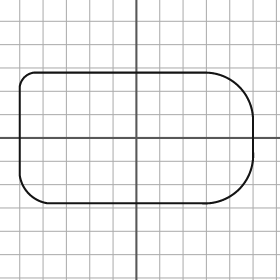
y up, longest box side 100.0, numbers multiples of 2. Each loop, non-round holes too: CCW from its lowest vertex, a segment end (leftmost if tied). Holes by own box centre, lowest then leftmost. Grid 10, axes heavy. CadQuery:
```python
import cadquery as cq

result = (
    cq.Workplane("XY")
    .moveTo(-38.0, -28.0)
    .lineTo(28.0, -28.0)
    .threePointArc((44.0, -22.0), (50.0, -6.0))
    .lineTo(50.0, 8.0)
    .threePointArc((44.0, 22.0), (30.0, 28.0))
    .lineTo(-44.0, 28.0)
    .threePointArc((-48.0, 26.0), (-50.0, 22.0))
    .lineTo(-50.0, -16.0)
    .threePointArc((-46.0, -24.0), (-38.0, -28.0))
    .close()
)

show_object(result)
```